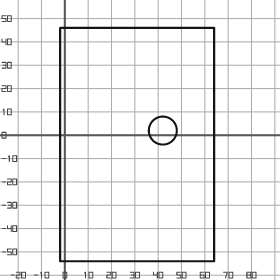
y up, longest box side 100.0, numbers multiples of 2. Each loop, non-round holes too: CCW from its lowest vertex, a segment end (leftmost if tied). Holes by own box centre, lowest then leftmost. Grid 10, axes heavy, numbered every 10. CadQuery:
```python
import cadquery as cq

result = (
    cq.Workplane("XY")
    .moveTo(-2.0, -54.0)
    .lineTo(64.0, -54.0)
    .lineTo(64.0, 46.0)
    .lineTo(-2.0, 46.0)
    .close()
    .moveTo(42.0, 2.0)
    .circle(6.0)
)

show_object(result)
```